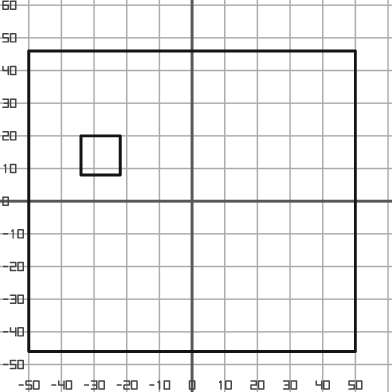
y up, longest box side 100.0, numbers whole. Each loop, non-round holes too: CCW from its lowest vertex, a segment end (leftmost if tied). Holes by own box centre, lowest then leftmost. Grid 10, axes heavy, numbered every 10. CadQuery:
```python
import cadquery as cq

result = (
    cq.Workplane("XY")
    .moveTo(-50.0, -46.0)
    .lineTo(50.0, -46.0)
    .lineTo(50.0, 46.0)
    .lineTo(-50.0, 46.0)
    .close()
    .moveTo(-34.0, 8.0)
    .lineTo(-22.0, 8.0)
    .lineTo(-22.0, 20.0)
    .lineTo(-34.0, 20.0)
    .close()
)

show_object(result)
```